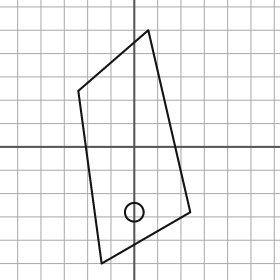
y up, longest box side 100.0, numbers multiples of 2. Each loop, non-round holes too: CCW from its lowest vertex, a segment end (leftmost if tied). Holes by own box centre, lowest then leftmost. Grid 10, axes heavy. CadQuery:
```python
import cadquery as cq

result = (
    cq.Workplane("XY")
    .moveTo(-14.0, -50.0)
    .lineTo(24.0, -28.0)
    .lineTo(6.0, 50.0)
    .lineTo(-24.0, 24.0)
    .close()
    .moveTo(0.0, -28.0)
    .circle(4.0)
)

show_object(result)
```